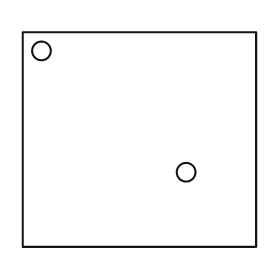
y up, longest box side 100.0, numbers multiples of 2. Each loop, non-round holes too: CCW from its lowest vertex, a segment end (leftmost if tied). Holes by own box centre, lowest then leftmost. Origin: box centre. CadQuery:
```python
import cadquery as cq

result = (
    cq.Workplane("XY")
    .moveTo(-50.0, -46.0)
    .lineTo(50.0, -46.0)
    .lineTo(50.0, 46.0)
    .lineTo(-50.0, 46.0)
    .close()
    .moveTo(20.0, -14.0)
    .circle(4.0)
    .moveTo(-42.0, 38.0)
    .circle(4.0)
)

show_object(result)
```